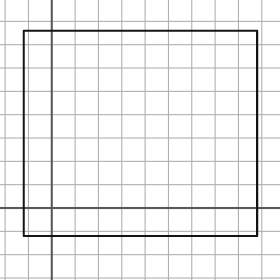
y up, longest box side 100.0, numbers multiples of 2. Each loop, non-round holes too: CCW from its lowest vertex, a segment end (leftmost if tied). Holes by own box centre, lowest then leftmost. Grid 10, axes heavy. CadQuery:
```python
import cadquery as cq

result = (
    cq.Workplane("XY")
    .moveTo(-12.0, -12.0)
    .lineTo(88.0, -12.0)
    .lineTo(88.0, 76.0)
    .lineTo(-12.0, 76.0)
    .close()
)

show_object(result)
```